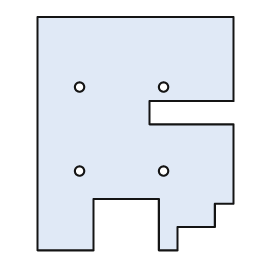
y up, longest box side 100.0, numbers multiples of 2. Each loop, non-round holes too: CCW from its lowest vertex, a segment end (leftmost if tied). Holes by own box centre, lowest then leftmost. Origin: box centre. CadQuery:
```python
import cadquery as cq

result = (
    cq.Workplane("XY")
    .moveTo(-42.0, -50.0)
    .lineTo(-18.0, -50.0)
    .lineTo(-18.0, -28.0)
    .lineTo(10.0, -28.0)
    .lineTo(10.0, -50.0)
    .lineTo(18.0, -50.0)
    .lineTo(18.0, -40.0)
    .lineTo(34.0, -40.0)
    .lineTo(34.0, -30.0)
    .lineTo(42.0, -30.0)
    .lineTo(42.0, 4.0)
    .lineTo(6.0, 4.0)
    .lineTo(6.0, 14.0)
    .lineTo(42.0, 14.0)
    .lineTo(42.0, 50.0)
    .lineTo(-42.0, 50.0)
    .close()
    .moveTo(-24.0, -16.0)
    .circle(2.0)
    .moveTo(12.0, -16.0)
    .circle(2.0)
    .moveTo(-24.0, 20.0)
    .circle(2.0)
    .moveTo(12.0, 20.0)
    .circle(2.0)
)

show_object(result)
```